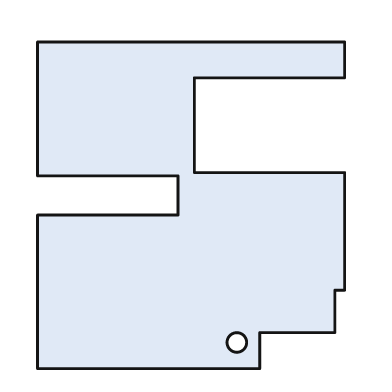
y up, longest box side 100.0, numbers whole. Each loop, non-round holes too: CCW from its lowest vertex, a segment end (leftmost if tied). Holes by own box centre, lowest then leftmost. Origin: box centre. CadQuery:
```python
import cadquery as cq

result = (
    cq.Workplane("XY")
    .moveTo(-47.0, -50.0)
    .lineTo(21.0, -50.0)
    .lineTo(21.0, -39.0)
    .lineTo(44.0, -39.0)
    .lineTo(44.0, -26.0)
    .lineTo(47.0, -26.0)
    .lineTo(47.0, 10.0)
    .lineTo(1.0, 10.0)
    .lineTo(1.0, 39.0)
    .lineTo(47.0, 39.0)
    .lineTo(47.0, 50.0)
    .lineTo(-47.0, 50.0)
    .lineTo(-47.0, 9.0)
    .lineTo(-4.0, 9.0)
    .lineTo(-4.0, -3.0)
    .lineTo(-47.0, -3.0)
    .close()
    .moveTo(14.0, -42.0)
    .circle(3.0)
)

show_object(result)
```